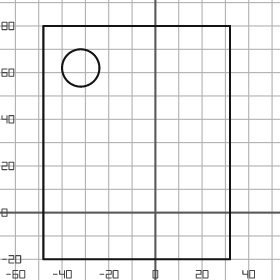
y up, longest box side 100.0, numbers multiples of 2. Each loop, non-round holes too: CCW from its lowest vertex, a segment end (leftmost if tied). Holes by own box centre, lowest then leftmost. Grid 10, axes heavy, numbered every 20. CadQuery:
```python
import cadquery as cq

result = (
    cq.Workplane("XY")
    .moveTo(-48.0, -20.0)
    .lineTo(32.0, -20.0)
    .lineTo(32.0, 80.0)
    .lineTo(-48.0, 80.0)
    .close()
    .moveTo(-32.0, 62.0)
    .circle(8.0)
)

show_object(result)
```